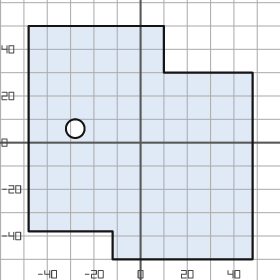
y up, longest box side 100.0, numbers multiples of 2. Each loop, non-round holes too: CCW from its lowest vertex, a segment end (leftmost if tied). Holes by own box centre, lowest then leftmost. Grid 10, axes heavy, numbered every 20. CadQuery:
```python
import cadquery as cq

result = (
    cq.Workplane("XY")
    .moveTo(-12.0, -50.0)
    .lineTo(48.0, -50.0)
    .lineTo(48.0, 30.0)
    .lineTo(10.0, 30.0)
    .lineTo(10.0, 50.0)
    .lineTo(-48.0, 50.0)
    .lineTo(-48.0, -38.0)
    .lineTo(-12.0, -38.0)
    .close()
    .moveTo(-28.0, 6.0)
    .circle(4.0)
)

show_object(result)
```